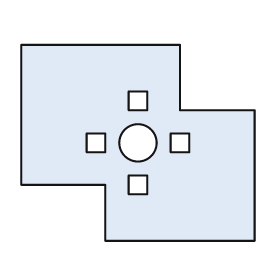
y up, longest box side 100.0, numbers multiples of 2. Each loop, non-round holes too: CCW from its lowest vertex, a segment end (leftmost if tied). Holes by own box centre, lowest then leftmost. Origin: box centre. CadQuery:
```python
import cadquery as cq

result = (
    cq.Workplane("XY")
    .moveTo(-14.0, -42.0)
    .lineTo(50.0, -42.0)
    .lineTo(50.0, 14.0)
    .lineTo(18.0, 14.0)
    .lineTo(18.0, 42.0)
    .lineTo(-50.0, 42.0)
    .lineTo(-50.0, -18.0)
    .lineTo(-14.0, -18.0)
    .close()
    .moveTo(-4.0, -22.0)
    .lineTo(4.0, -22.0)
    .lineTo(4.0, -14.0)
    .lineTo(-4.0, -14.0)
    .close()
    .moveTo(-22.0, -4.0)
    .lineTo(-14.0, -4.0)
    .lineTo(-14.0, 4.0)
    .lineTo(-22.0, 4.0)
    .close()
    .moveTo(0.0, 0.0)
    .circle(8.0)
    .moveTo(14.0, -4.0)
    .lineTo(22.0, -4.0)
    .lineTo(22.0, 4.0)
    .lineTo(14.0, 4.0)
    .close()
    .moveTo(-4.0, 14.0)
    .lineTo(4.0, 14.0)
    .lineTo(4.0, 22.0)
    .lineTo(-4.0, 22.0)
    .close()
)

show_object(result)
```